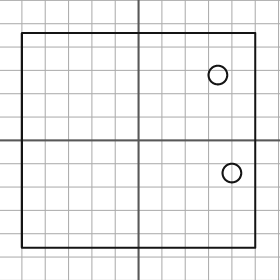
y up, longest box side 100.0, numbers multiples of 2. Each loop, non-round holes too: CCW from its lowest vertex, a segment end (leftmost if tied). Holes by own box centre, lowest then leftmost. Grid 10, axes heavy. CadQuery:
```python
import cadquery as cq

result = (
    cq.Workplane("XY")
    .moveTo(-50.0, -46.0)
    .lineTo(50.0, -46.0)
    .lineTo(50.0, 46.0)
    .lineTo(-50.0, 46.0)
    .close()
    .moveTo(40.0, -14.0)
    .circle(4.0)
    .moveTo(34.0, 28.0)
    .circle(4.0)
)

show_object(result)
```